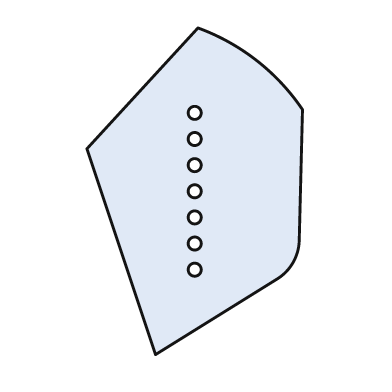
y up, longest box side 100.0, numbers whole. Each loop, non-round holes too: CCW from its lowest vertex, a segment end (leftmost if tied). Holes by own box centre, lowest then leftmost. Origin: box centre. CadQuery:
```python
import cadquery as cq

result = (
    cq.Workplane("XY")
    .moveTo(-12.0, -50.0)
    .lineTo(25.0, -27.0)
    .threePointArc((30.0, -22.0), (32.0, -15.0))
    .lineTo(33.0, 25.0)
    .threePointArc((19.0, 40.0), (1.0, 50.0))
    .lineTo(-33.0, 13.0)
    .close()
    .moveTo(0.0, -24.0)
    .circle(2.0)
    .moveTo(0.0, -16.0)
    .circle(2.0)
    .moveTo(0.0, -8.0)
    .circle(2.0)
    .moveTo(0.0, 0.0)
    .circle(2.0)
    .moveTo(0.0, 8.0)
    .circle(2.0)
    .moveTo(0.0, 16.0)
    .circle(2.0)
    .moveTo(0.0, 24.0)
    .circle(2.0)
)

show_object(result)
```